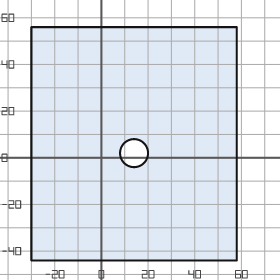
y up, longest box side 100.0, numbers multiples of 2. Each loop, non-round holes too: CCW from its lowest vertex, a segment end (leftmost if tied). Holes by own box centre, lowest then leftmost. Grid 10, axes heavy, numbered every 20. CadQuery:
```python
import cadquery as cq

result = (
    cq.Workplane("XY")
    .moveTo(-30.0, -44.0)
    .lineTo(58.0, -44.0)
    .lineTo(58.0, 56.0)
    .lineTo(-30.0, 56.0)
    .close()
    .moveTo(14.0, 2.0)
    .circle(6.0)
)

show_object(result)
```